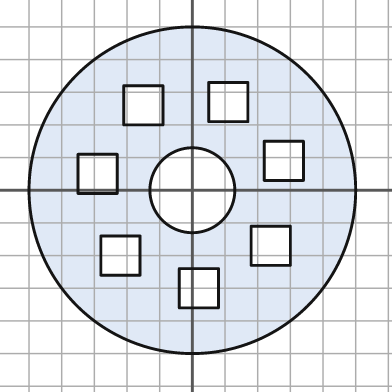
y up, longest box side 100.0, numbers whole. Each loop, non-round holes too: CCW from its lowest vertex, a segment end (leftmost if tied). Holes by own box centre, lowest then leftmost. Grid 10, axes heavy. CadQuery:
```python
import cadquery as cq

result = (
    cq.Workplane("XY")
    .moveTo(0.0, 0.0)
    .circle(50.0)
    .moveTo(-4.0, -36.0)
    .lineTo(8.0, -36.0)
    .lineTo(8.0, -24.0)
    .lineTo(-4.0, -24.0)
    .close()
    .moveTo(-28.0, -26.0)
    .lineTo(-16.0, -26.0)
    .lineTo(-16.0, -14.0)
    .lineTo(-28.0, -14.0)
    .close()
    .moveTo(18.0, -23.0)
    .lineTo(30.0, -23.0)
    .lineTo(30.0, -11.0)
    .lineTo(18.0, -11.0)
    .close()
    .moveTo(0.0, 0.0)
    .circle(13.0)
    .moveTo(-35.0, -1.0)
    .lineTo(-23.0, -1.0)
    .lineTo(-23.0, 11.0)
    .lineTo(-35.0, 11.0)
    .close()
    .moveTo(22.0, 3.0)
    .lineTo(34.0, 3.0)
    .lineTo(34.0, 15.0)
    .lineTo(22.0, 15.0)
    .close()
    .moveTo(-21.0, 20.0)
    .lineTo(-9.0, 20.0)
    .lineTo(-9.0, 32.0)
    .lineTo(-21.0, 32.0)
    .close()
    .moveTo(5.0, 21.0)
    .lineTo(17.0, 21.0)
    .lineTo(17.0, 33.0)
    .lineTo(5.0, 33.0)
    .close()
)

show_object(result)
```